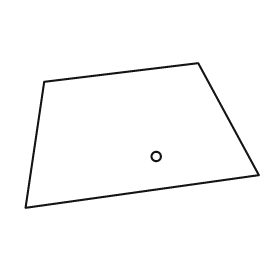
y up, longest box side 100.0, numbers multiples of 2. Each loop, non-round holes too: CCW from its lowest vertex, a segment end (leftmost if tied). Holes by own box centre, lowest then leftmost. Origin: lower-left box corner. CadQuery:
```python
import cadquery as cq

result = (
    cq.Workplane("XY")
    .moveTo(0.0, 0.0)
    .lineTo(100.0, 14.0)
    .lineTo(74.0, 62.0)
    .lineTo(8.0, 54.0)
    .close()
    .moveTo(56.0, 22.0)
    .circle(2.0)
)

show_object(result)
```